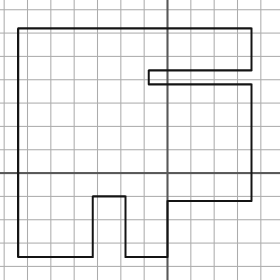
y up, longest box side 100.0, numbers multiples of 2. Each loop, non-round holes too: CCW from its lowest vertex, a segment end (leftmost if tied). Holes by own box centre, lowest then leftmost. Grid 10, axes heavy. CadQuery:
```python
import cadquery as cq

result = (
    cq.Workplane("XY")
    .moveTo(-64.0, -36.0)
    .lineTo(-32.0, -36.0)
    .lineTo(-32.0, -10.0)
    .lineTo(-18.0, -10.0)
    .lineTo(-18.0, -36.0)
    .lineTo(0.0, -36.0)
    .lineTo(0.0, -12.0)
    .lineTo(36.0, -12.0)
    .lineTo(36.0, 38.0)
    .lineTo(-8.0, 38.0)
    .lineTo(-8.0, 44.0)
    .lineTo(36.0, 44.0)
    .lineTo(36.0, 62.0)
    .lineTo(-64.0, 62.0)
    .close()
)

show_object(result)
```